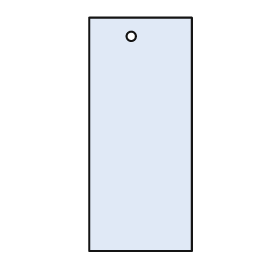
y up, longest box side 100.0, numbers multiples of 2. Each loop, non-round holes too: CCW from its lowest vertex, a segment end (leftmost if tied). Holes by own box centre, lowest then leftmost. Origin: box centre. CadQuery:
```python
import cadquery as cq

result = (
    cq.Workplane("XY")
    .moveTo(-22.0, -50.0)
    .lineTo(22.0, -50.0)
    .lineTo(22.0, 50.0)
    .lineTo(-22.0, 50.0)
    .close()
    .moveTo(-4.0, 42.0)
    .circle(2.0)
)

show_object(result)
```